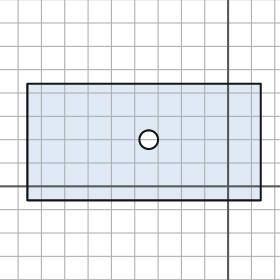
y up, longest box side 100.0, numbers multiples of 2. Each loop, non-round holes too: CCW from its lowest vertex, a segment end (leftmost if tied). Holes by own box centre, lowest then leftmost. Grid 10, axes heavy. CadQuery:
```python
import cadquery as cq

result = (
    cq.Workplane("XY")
    .moveTo(-86.0, -6.0)
    .lineTo(14.0, -6.0)
    .lineTo(14.0, 44.0)
    .lineTo(-86.0, 44.0)
    .close()
    .moveTo(-34.0, 20.0)
    .circle(4.0)
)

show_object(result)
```